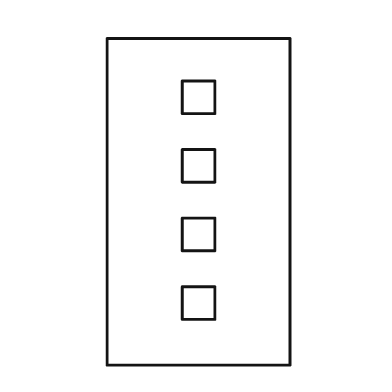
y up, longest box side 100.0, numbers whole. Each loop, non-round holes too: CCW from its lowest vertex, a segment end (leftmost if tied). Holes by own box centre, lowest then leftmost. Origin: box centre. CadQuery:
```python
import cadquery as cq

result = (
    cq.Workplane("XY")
    .moveTo(-28.0, -50.0)
    .lineTo(28.0, -50.0)
    .lineTo(28.0, 50.0)
    .lineTo(-28.0, 50.0)
    .close()
    .moveTo(-5.0, -36.0)
    .lineTo(5.0, -36.0)
    .lineTo(5.0, -26.0)
    .lineTo(-5.0, -26.0)
    .close()
    .moveTo(-5.0, -15.0)
    .lineTo(5.0, -15.0)
    .lineTo(5.0, -5.0)
    .lineTo(-5.0, -5.0)
    .close()
    .moveTo(-5.0, 6.0)
    .lineTo(5.0, 6.0)
    .lineTo(5.0, 16.0)
    .lineTo(-5.0, 16.0)
    .close()
    .moveTo(-5.0, 27.0)
    .lineTo(5.0, 27.0)
    .lineTo(5.0, 37.0)
    .lineTo(-5.0, 37.0)
    .close()
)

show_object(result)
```